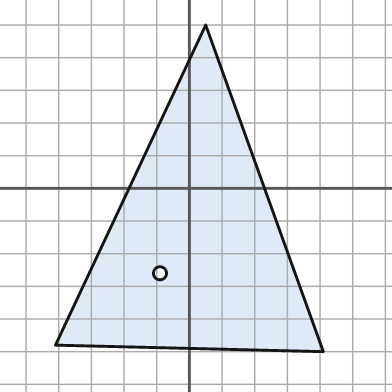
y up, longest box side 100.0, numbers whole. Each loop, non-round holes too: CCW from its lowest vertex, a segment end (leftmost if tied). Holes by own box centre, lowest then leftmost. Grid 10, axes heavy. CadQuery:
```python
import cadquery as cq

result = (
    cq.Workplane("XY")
    .moveTo(41.0, -50.0)
    .lineTo(5.0, 50.0)
    .lineTo(-41.0, -48.0)
    .close()
    .moveTo(-9.0, -26.0)
    .circle(2.0)
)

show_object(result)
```